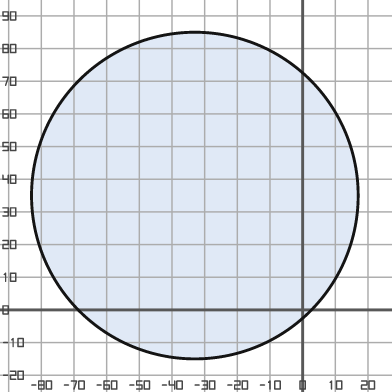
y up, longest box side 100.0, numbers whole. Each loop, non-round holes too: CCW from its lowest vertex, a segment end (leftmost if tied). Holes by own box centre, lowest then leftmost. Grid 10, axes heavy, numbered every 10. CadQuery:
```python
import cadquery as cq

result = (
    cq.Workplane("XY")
    .moveTo(-33.0, 35.0)
    .circle(50.0)
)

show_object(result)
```